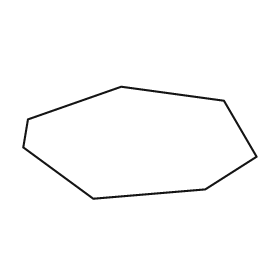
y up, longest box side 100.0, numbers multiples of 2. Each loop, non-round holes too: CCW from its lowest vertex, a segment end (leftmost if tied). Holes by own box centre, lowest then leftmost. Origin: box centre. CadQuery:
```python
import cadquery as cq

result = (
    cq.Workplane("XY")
    .moveTo(-20.0, -24.0)
    .lineTo(28.0, -20.0)
    .lineTo(50.0, -6.0)
    .lineTo(36.0, 18.0)
    .lineTo(-8.0, 24.0)
    .lineTo(-48.0, 10.0)
    .lineTo(-50.0, -2.0)
    .close()
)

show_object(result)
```